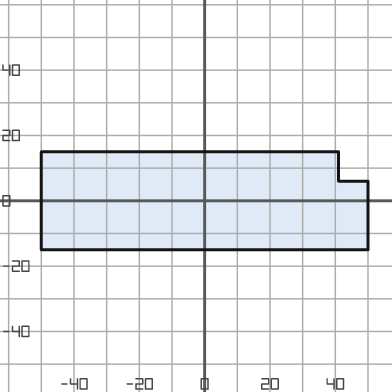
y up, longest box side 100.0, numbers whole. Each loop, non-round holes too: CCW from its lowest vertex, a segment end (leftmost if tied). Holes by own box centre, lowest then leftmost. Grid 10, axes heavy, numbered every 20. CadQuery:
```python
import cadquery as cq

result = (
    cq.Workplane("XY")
    .moveTo(-50.0, -15.0)
    .lineTo(50.0, -15.0)
    .lineTo(50.0, 6.0)
    .lineTo(41.0, 6.0)
    .lineTo(41.0, 15.0)
    .lineTo(-50.0, 15.0)
    .close()
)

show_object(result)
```